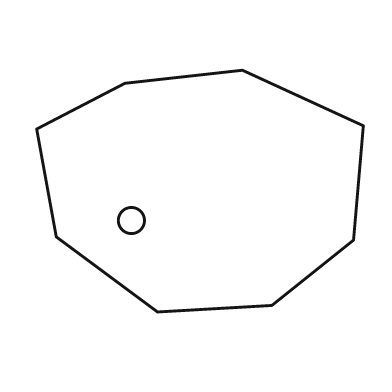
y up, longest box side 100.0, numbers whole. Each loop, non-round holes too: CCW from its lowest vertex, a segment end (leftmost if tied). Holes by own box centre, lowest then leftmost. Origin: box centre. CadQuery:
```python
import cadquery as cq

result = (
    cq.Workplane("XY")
    .moveTo(-13.0, -37.0)
    .lineTo(22.0, -35.0)
    .lineTo(47.0, -15.0)
    .lineTo(50.0, 20.0)
    .lineTo(13.0, 37.0)
    .lineTo(-23.0, 33.0)
    .lineTo(-50.0, 19.0)
    .lineTo(-44.0, -14.0)
    .close()
    .moveTo(-21.0, -9.0)
    .circle(4.0)
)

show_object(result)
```